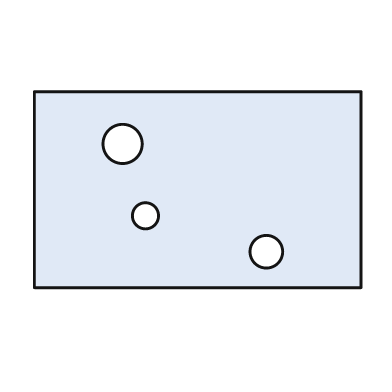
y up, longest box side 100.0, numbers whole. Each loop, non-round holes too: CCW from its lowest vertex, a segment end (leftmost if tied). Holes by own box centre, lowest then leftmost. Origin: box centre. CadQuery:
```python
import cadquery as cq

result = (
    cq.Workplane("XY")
    .moveTo(-50.0, -30.0)
    .lineTo(50.0, -30.0)
    .lineTo(50.0, 30.0)
    .lineTo(-50.0, 30.0)
    .close()
    .moveTo(21.0, -19.0)
    .circle(5.0)
    .moveTo(-16.0, -8.0)
    .circle(4.0)
    .moveTo(-23.0, 14.0)
    .circle(6.0)
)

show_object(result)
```